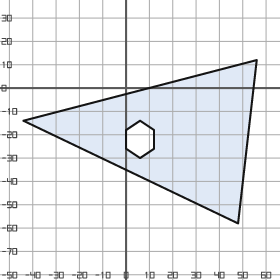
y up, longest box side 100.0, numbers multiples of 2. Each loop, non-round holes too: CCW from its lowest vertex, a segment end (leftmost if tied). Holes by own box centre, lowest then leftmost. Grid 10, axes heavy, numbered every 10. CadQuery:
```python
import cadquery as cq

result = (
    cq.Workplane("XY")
    .moveTo(48.0, -58.0)
    .lineTo(56.0, 12.0)
    .lineTo(-44.0, -14.0)
    .close()
    .moveTo(6.0, -30.0)
    .lineTo(12.0, -26.0)
    .lineTo(12.0, -18.0)
    .lineTo(6.0, -14.0)
    .lineTo(0.0, -18.0)
    .lineTo(0.0, -26.0)
    .close()
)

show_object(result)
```